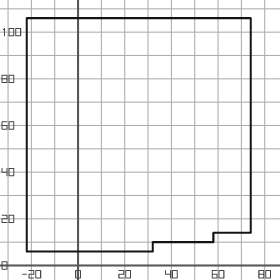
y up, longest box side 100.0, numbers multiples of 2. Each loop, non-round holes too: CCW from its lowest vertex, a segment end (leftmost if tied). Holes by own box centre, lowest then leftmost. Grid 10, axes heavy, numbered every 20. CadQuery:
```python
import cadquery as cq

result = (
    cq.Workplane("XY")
    .moveTo(-22.0, 6.0)
    .lineTo(32.0, 6.0)
    .lineTo(32.0, 10.0)
    .lineTo(58.0, 10.0)
    .lineTo(58.0, 14.0)
    .lineTo(74.0, 14.0)
    .lineTo(74.0, 106.0)
    .lineTo(-22.0, 106.0)
    .close()
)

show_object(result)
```